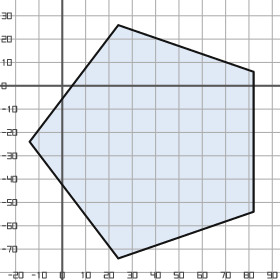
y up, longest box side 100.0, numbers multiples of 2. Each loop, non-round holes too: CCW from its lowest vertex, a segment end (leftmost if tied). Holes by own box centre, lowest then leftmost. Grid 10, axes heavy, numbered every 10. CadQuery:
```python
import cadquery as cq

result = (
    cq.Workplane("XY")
    .moveTo(24.0, -74.0)
    .lineTo(82.0, -54.0)
    .lineTo(82.0, 6.0)
    .lineTo(24.0, 26.0)
    .lineTo(-14.0, -24.0)
    .close()
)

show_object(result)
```